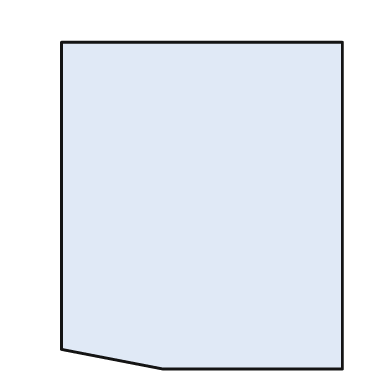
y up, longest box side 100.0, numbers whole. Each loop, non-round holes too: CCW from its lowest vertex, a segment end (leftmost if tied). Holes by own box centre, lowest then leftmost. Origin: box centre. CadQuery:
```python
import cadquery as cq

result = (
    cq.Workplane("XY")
    .moveTo(-12.0, -50.0)
    .lineTo(43.0, -50.0)
    .lineTo(43.0, 50.0)
    .lineTo(-43.0, 50.0)
    .lineTo(-43.0, -44.0)
    .close()
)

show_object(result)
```